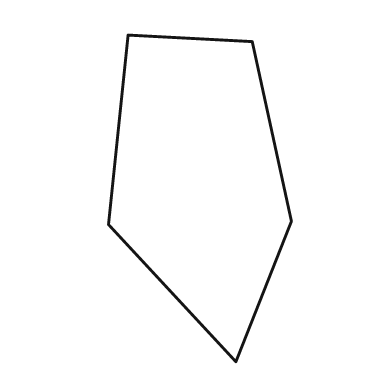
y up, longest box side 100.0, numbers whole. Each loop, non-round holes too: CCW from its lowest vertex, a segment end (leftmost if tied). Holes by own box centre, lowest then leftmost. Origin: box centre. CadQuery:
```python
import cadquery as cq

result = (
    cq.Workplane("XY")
    .moveTo(11.0, -50.0)
    .lineTo(28.0, -7.0)
    .lineTo(16.0, 48.0)
    .lineTo(-22.0, 50.0)
    .lineTo(-28.0, -8.0)
    .close()
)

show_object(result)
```